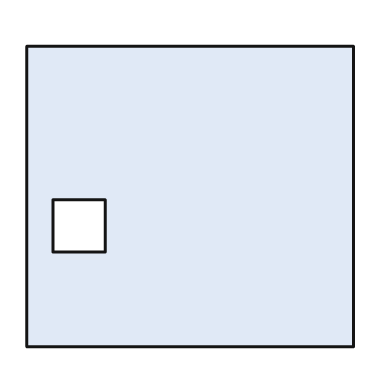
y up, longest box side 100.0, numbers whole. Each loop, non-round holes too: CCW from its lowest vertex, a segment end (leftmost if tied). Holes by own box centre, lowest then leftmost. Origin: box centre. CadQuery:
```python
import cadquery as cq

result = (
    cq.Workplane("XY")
    .moveTo(-50.0, -46.0)
    .lineTo(50.0, -46.0)
    .lineTo(50.0, 46.0)
    .lineTo(-50.0, 46.0)
    .close()
    .moveTo(-42.0, -17.0)
    .lineTo(-26.0, -17.0)
    .lineTo(-26.0, -1.0)
    .lineTo(-42.0, -1.0)
    .close()
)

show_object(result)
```